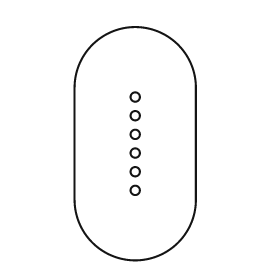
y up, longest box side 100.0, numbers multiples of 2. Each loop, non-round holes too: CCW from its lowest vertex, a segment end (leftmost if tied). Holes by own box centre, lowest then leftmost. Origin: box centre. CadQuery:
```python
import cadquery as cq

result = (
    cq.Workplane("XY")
    .moveTo(-26.0, -24.0)
    .threePointArc((0.0, -50.0), (26.0, -24.0))
    .lineTo(26.0, 24.0)
    .threePointArc((0.0, 50.0), (-26.0, 24.0))
    .close()
    .moveTo(0.0, -20.0)
    .circle(2.0)
    .moveTo(0.0, -12.0)
    .circle(2.0)
    .moveTo(0.0, -4.0)
    .circle(2.0)
    .moveTo(0.0, 4.0)
    .circle(2.0)
    .moveTo(0.0, 12.0)
    .circle(2.0)
    .moveTo(0.0, 20.0)
    .circle(2.0)
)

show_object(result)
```